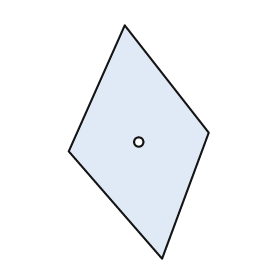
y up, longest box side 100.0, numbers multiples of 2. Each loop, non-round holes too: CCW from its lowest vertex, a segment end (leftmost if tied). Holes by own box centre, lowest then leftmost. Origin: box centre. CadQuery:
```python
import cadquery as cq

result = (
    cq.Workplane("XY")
    .moveTo(10.0, -50.0)
    .lineTo(30.0, 4.0)
    .lineTo(-6.0, 50.0)
    .lineTo(-30.0, -4.0)
    .close()
    .moveTo(0.0, 0.0)
    .circle(2.0)
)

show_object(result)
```